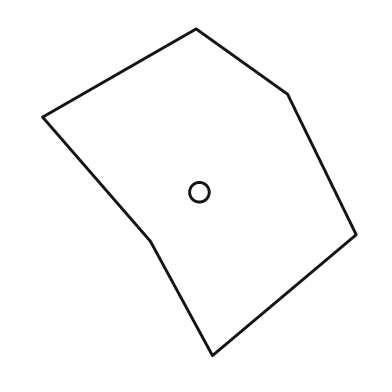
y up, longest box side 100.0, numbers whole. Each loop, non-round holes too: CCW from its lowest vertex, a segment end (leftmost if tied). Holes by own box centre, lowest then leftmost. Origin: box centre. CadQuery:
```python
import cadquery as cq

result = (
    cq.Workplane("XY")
    .moveTo(4.0, -50.0)
    .lineTo(48.0, -13.0)
    .lineTo(27.0, 30.0)
    .lineTo(-1.0, 50.0)
    .lineTo(-48.0, 23.0)
    .lineTo(-15.0, -15.0)
    .close()
    .moveTo(0.0, 0.0)
    .circle(3.0)
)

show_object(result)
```